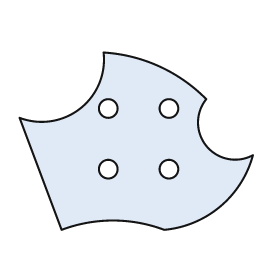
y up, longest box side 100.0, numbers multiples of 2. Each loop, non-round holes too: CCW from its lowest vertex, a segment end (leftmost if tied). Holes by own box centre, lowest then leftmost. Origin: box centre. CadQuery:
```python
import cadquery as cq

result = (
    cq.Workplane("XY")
    .moveTo(-32.0, -38.0)
    .threePointArc((-10.0, -34.0), (12.0, -38.0))
    .threePointArc((36.0, -28.0), (50.0, -6.0))
    .threePointArc((30.0, -2.0), (30.0, 18.0))
    .threePointArc((10.0, 32.0), (-14.0, 38.0))
    .threePointArc((-24.0, 14.0), (-50.0, 10.0))
    .close()
    .moveTo(-12.0, -12.0)
    .circle(4.0)
    .moveTo(14.0, -12.0)
    .circle(4.0)
    .moveTo(-12.0, 14.0)
    .circle(4.0)
    .moveTo(14.0, 14.0)
    .circle(4.0)
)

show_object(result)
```